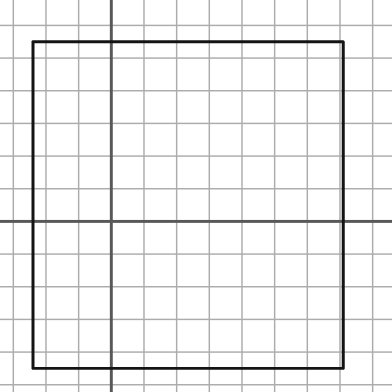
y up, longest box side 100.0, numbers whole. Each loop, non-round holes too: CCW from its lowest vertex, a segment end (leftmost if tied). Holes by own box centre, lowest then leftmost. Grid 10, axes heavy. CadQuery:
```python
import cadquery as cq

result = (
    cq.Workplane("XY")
    .moveTo(-24.0, -45.0)
    .lineTo(71.0, -45.0)
    .lineTo(71.0, 55.0)
    .lineTo(-24.0, 55.0)
    .close()
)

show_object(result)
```